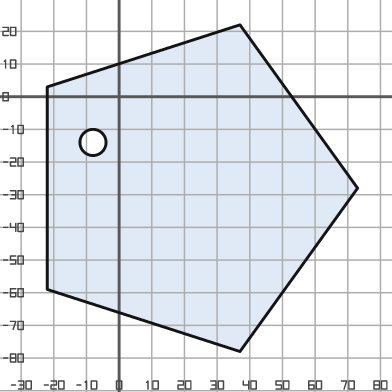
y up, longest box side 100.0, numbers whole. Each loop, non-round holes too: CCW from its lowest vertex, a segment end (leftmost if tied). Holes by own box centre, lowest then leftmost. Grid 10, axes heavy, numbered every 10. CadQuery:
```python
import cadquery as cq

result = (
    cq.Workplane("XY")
    .moveTo(37.0, -78.0)
    .lineTo(73.0, -28.0)
    .lineTo(37.0, 22.0)
    .lineTo(-22.0, 3.0)
    .lineTo(-22.0, -59.0)
    .close()
    .moveTo(-8.0, -14.0)
    .circle(4.0)
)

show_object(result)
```